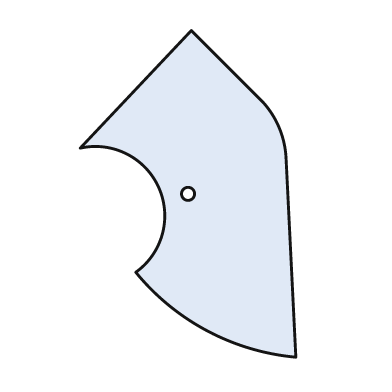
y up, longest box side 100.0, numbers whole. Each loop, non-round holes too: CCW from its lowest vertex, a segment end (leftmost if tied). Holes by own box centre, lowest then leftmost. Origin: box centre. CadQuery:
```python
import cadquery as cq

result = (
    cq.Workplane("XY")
    .moveTo(33.0, -50.0)
    .lineTo(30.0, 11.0)
    .threePointArc((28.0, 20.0), (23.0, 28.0))
    .lineTo(1.0, 50.0)
    .lineTo(-33.0, 14.0)
    .threePointArc((-9.0, 2.0), (-16.0, -24.0))
    .threePointArc((6.0, -42.0), (33.0, -50.0))
    .close()
    .moveTo(0.0, 0.0)
    .circle(2.0)
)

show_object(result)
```